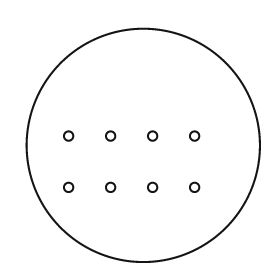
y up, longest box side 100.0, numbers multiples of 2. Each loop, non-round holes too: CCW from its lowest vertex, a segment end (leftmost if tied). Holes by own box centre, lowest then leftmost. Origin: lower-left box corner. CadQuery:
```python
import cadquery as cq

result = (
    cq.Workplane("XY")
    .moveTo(50.0, 50.0)
    .circle(50.0)
    .moveTo(18.0, 32.0)
    .circle(2.0)
    .moveTo(36.0, 32.0)
    .circle(2.0)
    .moveTo(54.0, 32.0)
    .circle(2.0)
    .moveTo(72.0, 32.0)
    .circle(2.0)
    .moveTo(18.0, 54.0)
    .circle(2.0)
    .moveTo(36.0, 54.0)
    .circle(2.0)
    .moveTo(54.0, 54.0)
    .circle(2.0)
    .moveTo(72.0, 54.0)
    .circle(2.0)
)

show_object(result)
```